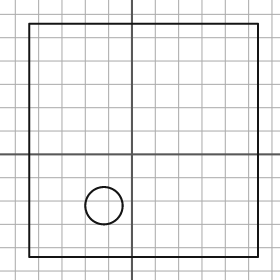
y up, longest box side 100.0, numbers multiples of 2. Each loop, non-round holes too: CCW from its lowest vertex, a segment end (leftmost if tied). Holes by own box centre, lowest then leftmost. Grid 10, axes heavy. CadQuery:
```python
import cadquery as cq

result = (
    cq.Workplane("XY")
    .moveTo(-44.0, -44.0)
    .lineTo(54.0, -44.0)
    .lineTo(54.0, 56.0)
    .lineTo(-44.0, 56.0)
    .close()
    .moveTo(-12.0, -22.0)
    .circle(8.0)
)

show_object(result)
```